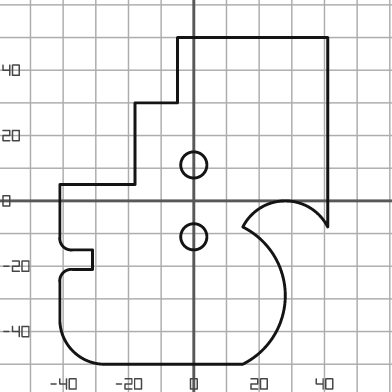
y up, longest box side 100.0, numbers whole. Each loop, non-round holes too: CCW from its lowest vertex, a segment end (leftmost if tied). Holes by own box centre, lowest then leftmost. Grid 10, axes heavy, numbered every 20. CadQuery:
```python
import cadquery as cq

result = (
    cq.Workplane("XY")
    .moveTo(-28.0, -50.0)
    .lineTo(15.0, -50.0)
    .threePointArc((28.0, -29.0), (15.0, -8.0))
    .threePointArc((28.0, 0.0), (41.0, -8.0))
    .lineTo(41.0, 50.0)
    .lineTo(-5.0, 50.0)
    .lineTo(-5.0, 30.0)
    .lineTo(-18.0, 30.0)
    .lineTo(-18.0, 5.0)
    .lineTo(-41.0, 5.0)
    .lineTo(-41.0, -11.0)
    .threePointArc((-40.0, -14.0), (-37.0, -15.0))
    .lineTo(-31.0, -15.0)
    .lineTo(-31.0, -21.0)
    .lineTo(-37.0, -21.0)
    .threePointArc((-40.0, -22.0), (-41.0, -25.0))
    .lineTo(-41.0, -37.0)
    .threePointArc((-37.0, -46.0), (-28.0, -50.0))
    .close()
    .moveTo(0.0, -11.0)
    .circle(4.0)
    .moveTo(0.0, 11.0)
    .circle(4.0)
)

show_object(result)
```